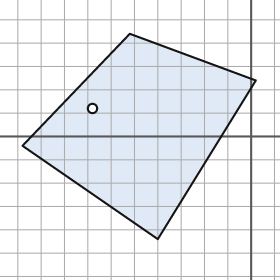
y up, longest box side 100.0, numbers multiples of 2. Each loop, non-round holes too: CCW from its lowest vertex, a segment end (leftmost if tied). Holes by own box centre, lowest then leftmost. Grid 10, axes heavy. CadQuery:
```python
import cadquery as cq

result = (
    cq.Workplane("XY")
    .moveTo(-40.0, -44.0)
    .lineTo(2.0, 24.0)
    .lineTo(-52.0, 44.0)
    .lineTo(-98.0, -4.0)
    .close()
    .moveTo(-68.0, 12.0)
    .circle(2.0)
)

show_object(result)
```